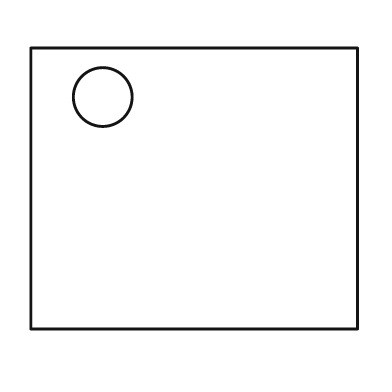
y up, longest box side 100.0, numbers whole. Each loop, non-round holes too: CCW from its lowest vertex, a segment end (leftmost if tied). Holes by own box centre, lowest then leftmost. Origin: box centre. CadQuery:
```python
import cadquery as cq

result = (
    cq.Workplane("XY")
    .moveTo(-50.0, -43.0)
    .lineTo(50.0, -43.0)
    .lineTo(50.0, 43.0)
    .lineTo(-50.0, 43.0)
    .close()
    .moveTo(-28.0, 28.0)
    .circle(9.0)
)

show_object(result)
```